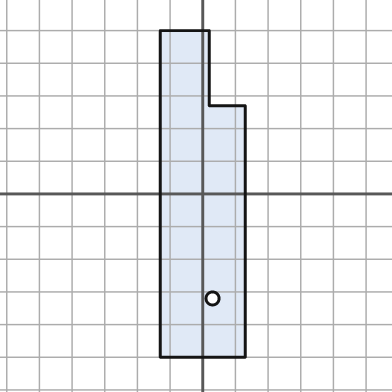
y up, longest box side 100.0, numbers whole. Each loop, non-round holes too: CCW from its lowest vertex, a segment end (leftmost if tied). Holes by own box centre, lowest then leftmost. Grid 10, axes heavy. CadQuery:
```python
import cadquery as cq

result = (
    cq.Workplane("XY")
    .moveTo(-13.0, -50.0)
    .lineTo(13.0, -50.0)
    .lineTo(13.0, 27.0)
    .lineTo(2.0, 27.0)
    .lineTo(2.0, 50.0)
    .lineTo(-13.0, 50.0)
    .close()
    .moveTo(3.0, -32.0)
    .circle(2.0)
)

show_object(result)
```